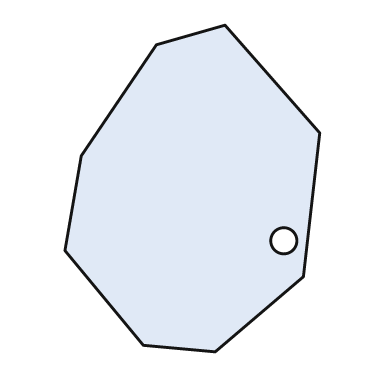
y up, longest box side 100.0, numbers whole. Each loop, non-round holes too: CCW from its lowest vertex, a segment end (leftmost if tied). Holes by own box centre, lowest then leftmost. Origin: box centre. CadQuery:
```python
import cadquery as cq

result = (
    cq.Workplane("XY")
    .moveTo(7.0, -50.0)
    .lineTo(34.0, -27.0)
    .lineTo(39.0, 17.0)
    .lineTo(10.0, 50.0)
    .lineTo(-11.0, 44.0)
    .lineTo(-34.0, 10.0)
    .lineTo(-39.0, -19.0)
    .lineTo(-15.0, -48.0)
    .close()
    .moveTo(28.0, -16.0)
    .circle(4.0)
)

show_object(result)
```